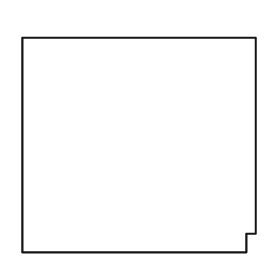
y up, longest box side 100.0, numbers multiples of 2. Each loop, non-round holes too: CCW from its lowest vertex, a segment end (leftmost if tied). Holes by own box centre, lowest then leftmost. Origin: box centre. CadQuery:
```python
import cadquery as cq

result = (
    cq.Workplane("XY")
    .moveTo(-50.0, -46.0)
    .lineTo(46.0, -46.0)
    .lineTo(46.0, -38.0)
    .lineTo(50.0, -38.0)
    .lineTo(50.0, 46.0)
    .lineTo(-50.0, 46.0)
    .close()
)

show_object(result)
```